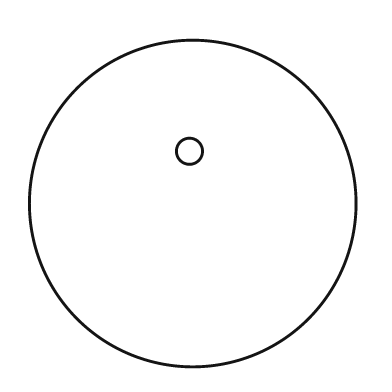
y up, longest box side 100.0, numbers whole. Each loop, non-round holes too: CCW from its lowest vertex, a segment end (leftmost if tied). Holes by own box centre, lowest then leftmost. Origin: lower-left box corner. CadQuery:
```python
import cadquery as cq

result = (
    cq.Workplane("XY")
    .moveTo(50.0, 50.0)
    .circle(50.0)
    .moveTo(49.0, 66.0)
    .circle(4.0)
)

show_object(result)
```